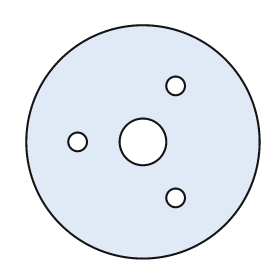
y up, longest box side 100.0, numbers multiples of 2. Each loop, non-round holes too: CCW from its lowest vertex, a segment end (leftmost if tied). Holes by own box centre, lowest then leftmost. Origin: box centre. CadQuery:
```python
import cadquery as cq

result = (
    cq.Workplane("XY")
    .moveTo(0.0, 0.0)
    .circle(50.0)
    .moveTo(14.0, -24.0)
    .circle(4.0)
    .moveTo(-28.0, 0.0)
    .circle(4.0)
    .moveTo(0.0, 0.0)
    .circle(10.0)
    .moveTo(14.0, 24.0)
    .circle(4.0)
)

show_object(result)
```